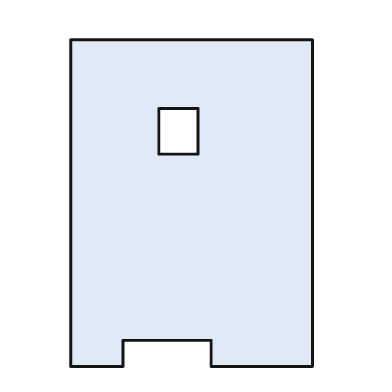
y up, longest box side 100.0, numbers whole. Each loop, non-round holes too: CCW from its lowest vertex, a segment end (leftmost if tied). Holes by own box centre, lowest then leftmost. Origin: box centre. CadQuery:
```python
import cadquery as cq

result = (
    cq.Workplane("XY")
    .moveTo(-37.0, -50.0)
    .lineTo(-21.0, -50.0)
    .lineTo(-21.0, -42.0)
    .lineTo(6.0, -42.0)
    .lineTo(6.0, -50.0)
    .lineTo(37.0, -50.0)
    .lineTo(37.0, 50.0)
    .lineTo(-37.0, 50.0)
    .close()
    .moveTo(-10.0, 15.0)
    .lineTo(2.0, 15.0)
    .lineTo(2.0, 29.0)
    .lineTo(-10.0, 29.0)
    .close()
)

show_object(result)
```